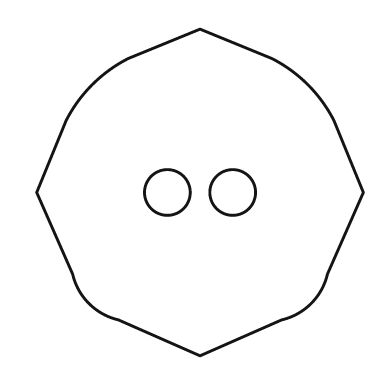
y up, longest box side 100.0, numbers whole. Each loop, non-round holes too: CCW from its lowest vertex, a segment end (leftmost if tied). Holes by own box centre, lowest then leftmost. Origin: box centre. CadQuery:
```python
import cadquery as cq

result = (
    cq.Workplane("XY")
    .moveTo(0.0, -50.0)
    .lineTo(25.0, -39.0)
    .threePointArc((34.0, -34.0), (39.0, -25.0))
    .lineTo(50.0, 0.0)
    .lineTo(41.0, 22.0)
    .threePointArc((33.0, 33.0), (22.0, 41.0))
    .lineTo(0.0, 50.0)
    .lineTo(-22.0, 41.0)
    .threePointArc((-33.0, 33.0), (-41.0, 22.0))
    .lineTo(-50.0, 0.0)
    .lineTo(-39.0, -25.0)
    .threePointArc((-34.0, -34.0), (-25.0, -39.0))
    .close()
    .moveTo(-10.0, 0.0)
    .circle(7.0)
    .moveTo(10.0, 0.0)
    .circle(7.0)
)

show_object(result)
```